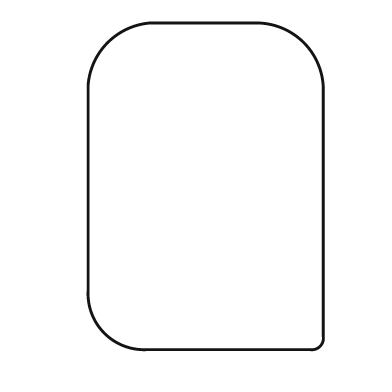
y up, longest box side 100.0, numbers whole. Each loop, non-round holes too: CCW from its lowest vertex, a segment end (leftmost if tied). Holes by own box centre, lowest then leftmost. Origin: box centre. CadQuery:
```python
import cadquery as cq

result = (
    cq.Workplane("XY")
    .moveTo(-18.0, -50.0)
    .lineTo(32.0, -50.0)
    .threePointArc((35.0, -49.0), (36.0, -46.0))
    .lineTo(36.0, 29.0)
    .threePointArc((30.0, 44.0), (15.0, 50.0))
    .lineTo(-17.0, 50.0)
    .threePointArc((-30.0, 44.0), (-36.0, 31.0))
    .lineTo(-36.0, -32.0)
    .threePointArc((-31.0, -45.0), (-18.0, -50.0))
    .close()
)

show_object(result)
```